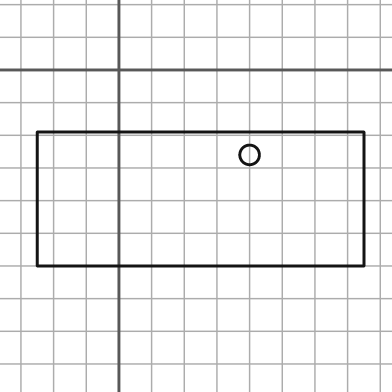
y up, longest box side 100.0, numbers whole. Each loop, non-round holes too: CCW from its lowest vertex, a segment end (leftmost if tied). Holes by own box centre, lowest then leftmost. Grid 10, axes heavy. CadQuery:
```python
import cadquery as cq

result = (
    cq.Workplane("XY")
    .moveTo(-25.0, -60.0)
    .lineTo(75.0, -60.0)
    .lineTo(75.0, -19.0)
    .lineTo(-25.0, -19.0)
    .close()
    .moveTo(40.0, -26.0)
    .circle(3.0)
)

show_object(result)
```